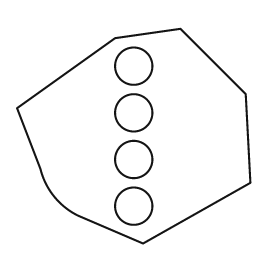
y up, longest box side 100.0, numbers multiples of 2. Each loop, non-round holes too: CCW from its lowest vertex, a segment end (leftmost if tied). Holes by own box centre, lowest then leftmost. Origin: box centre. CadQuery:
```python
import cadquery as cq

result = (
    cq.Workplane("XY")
    .moveTo(4.0, -46.0)
    .lineTo(50.0, -20.0)
    .lineTo(48.0, 18.0)
    .lineTo(20.0, 46.0)
    .lineTo(-8.0, 42.0)
    .lineTo(-50.0, 12.0)
    .lineTo(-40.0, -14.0)
    .threePointArc((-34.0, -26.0), (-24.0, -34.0))
    .close()
    .moveTo(0.0, -30.0)
    .circle(8.0)
    .moveTo(0.0, -10.0)
    .circle(8.0)
    .moveTo(0.0, 10.0)
    .circle(8.0)
    .moveTo(0.0, 30.0)
    .circle(8.0)
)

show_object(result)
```